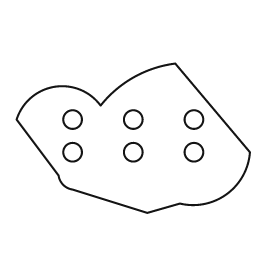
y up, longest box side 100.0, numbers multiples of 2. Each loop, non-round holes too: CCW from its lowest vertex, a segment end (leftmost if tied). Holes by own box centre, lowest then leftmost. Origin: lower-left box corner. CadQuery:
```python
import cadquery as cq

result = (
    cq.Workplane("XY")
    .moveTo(56.0, 0.0)
    .lineTo(70.0, 4.0)
    .threePointArc((90.0, 8.0), (100.0, 26.0))
    .lineTo(68.0, 64.0)
    .threePointArc((50.0, 58.0), (36.0, 46.0))
    .threePointArc((16.0, 54.0), (0.0, 40.0))
    .lineTo(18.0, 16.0)
    .threePointArc((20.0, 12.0), (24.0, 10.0))
    .close()
    .moveTo(24.0, 26.0)
    .circle(4.0)
    .moveTo(50.0, 26.0)
    .circle(4.0)
    .moveTo(76.0, 26.0)
    .circle(4.0)
    .moveTo(24.0, 40.0)
    .circle(4.0)
    .moveTo(50.0, 40.0)
    .circle(4.0)
    .moveTo(76.0, 40.0)
    .circle(4.0)
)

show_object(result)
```